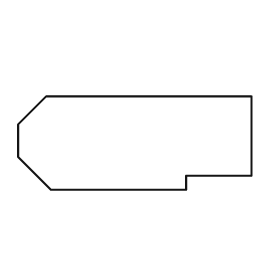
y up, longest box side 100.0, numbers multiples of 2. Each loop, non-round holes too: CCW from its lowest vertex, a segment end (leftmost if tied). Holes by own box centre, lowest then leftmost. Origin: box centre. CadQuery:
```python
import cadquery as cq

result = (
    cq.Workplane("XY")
    .moveTo(-36.0, -20.0)
    .lineTo(22.0, -20.0)
    .lineTo(22.0, -14.0)
    .lineTo(50.0, -14.0)
    .lineTo(50.0, 20.0)
    .lineTo(-38.0, 20.0)
    .lineTo(-50.0, 8.0)
    .lineTo(-50.0, -6.0)
    .close()
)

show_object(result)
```